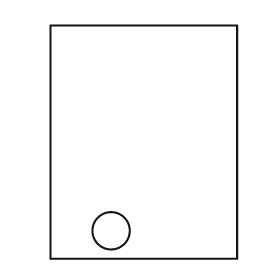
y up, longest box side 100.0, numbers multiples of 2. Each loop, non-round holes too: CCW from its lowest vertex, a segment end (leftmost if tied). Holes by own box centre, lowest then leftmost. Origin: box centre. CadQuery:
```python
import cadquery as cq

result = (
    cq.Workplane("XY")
    .moveTo(-40.0, -50.0)
    .lineTo(40.0, -50.0)
    .lineTo(40.0, 50.0)
    .lineTo(-40.0, 50.0)
    .close()
    .moveTo(-14.0, -38.0)
    .circle(8.0)
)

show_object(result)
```